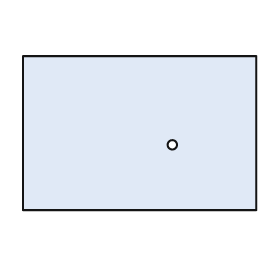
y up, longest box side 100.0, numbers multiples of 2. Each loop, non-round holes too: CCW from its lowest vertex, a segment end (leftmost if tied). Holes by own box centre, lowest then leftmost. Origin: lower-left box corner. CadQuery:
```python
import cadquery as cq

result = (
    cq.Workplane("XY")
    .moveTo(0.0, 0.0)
    .lineTo(100.0, 0.0)
    .lineTo(100.0, 66.0)
    .lineTo(0.0, 66.0)
    .close()
    .moveTo(64.0, 28.0)
    .circle(2.0)
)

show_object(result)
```